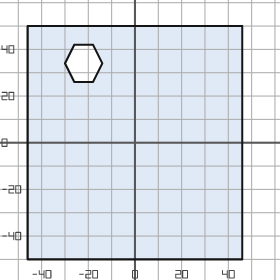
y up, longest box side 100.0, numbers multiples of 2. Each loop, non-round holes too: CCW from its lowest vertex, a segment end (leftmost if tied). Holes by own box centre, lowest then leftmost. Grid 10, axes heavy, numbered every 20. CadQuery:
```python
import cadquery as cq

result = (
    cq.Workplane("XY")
    .moveTo(-46.0, -50.0)
    .lineTo(46.0, -50.0)
    .lineTo(46.0, 50.0)
    .lineTo(-46.0, 50.0)
    .close()
    .moveTo(-26.0, 26.0)
    .lineTo(-18.0, 26.0)
    .lineTo(-14.0, 34.0)
    .lineTo(-18.0, 42.0)
    .lineTo(-26.0, 42.0)
    .lineTo(-30.0, 34.0)
    .close()
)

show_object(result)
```